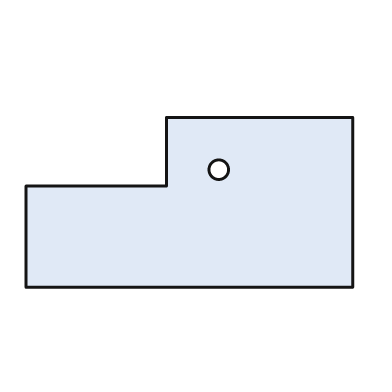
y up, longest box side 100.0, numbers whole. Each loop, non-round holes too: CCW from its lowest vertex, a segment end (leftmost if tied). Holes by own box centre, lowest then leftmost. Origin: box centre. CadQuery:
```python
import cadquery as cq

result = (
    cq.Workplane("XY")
    .moveTo(-50.0, -26.0)
    .lineTo(50.0, -26.0)
    .lineTo(50.0, 26.0)
    .lineTo(-7.0, 26.0)
    .lineTo(-7.0, 5.0)
    .lineTo(-50.0, 5.0)
    .close()
    .moveTo(9.0, 10.0)
    .circle(3.0)
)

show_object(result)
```